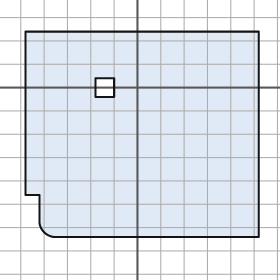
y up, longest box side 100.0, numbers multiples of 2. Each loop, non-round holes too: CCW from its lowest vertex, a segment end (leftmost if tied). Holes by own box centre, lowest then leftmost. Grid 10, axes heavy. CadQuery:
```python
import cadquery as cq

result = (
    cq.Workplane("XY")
    .moveTo(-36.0, -64.0)
    .lineTo(52.0, -64.0)
    .lineTo(52.0, 24.0)
    .lineTo(-48.0, 24.0)
    .lineTo(-48.0, -46.0)
    .lineTo(-42.0, -46.0)
    .lineTo(-42.0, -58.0)
    .threePointArc((-40.0, -62.0), (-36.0, -64.0))
    .close()
    .moveTo(-18.0, -4.0)
    .lineTo(-10.0, -4.0)
    .lineTo(-10.0, 4.0)
    .lineTo(-18.0, 4.0)
    .close()
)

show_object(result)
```